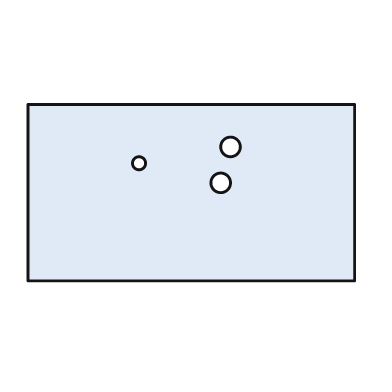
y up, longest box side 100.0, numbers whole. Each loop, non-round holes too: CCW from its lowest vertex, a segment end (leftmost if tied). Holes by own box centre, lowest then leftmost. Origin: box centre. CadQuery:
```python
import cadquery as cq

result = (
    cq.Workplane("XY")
    .moveTo(-50.0, -27.0)
    .lineTo(50.0, -27.0)
    .lineTo(50.0, 27.0)
    .lineTo(-50.0, 27.0)
    .close()
    .moveTo(9.0, 3.0)
    .circle(3.0)
    .moveTo(-16.0, 9.0)
    .circle(2.0)
    .moveTo(12.0, 14.0)
    .circle(3.0)
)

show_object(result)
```